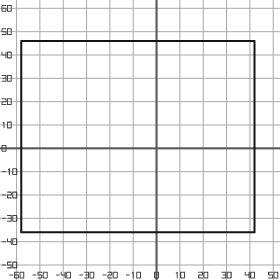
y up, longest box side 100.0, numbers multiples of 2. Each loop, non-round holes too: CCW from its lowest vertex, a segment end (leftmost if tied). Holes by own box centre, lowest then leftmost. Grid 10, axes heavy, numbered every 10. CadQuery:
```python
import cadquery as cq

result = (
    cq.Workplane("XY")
    .moveTo(-58.0, -36.0)
    .lineTo(42.0, -36.0)
    .lineTo(42.0, 46.0)
    .lineTo(-58.0, 46.0)
    .close()
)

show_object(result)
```